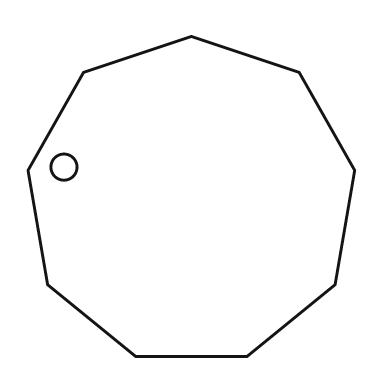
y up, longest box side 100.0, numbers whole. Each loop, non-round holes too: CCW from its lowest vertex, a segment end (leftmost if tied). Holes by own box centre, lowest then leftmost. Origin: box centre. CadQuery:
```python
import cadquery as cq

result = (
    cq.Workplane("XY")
    .moveTo(-17.0, -49.0)
    .lineTo(17.0, -49.0)
    .lineTo(44.0, -27.0)
    .lineTo(50.0, 8.0)
    .lineTo(33.0, 38.0)
    .lineTo(0.0, 49.0)
    .lineTo(-33.0, 38.0)
    .lineTo(-50.0, 8.0)
    .lineTo(-44.0, -27.0)
    .close()
    .moveTo(-39.0, 9.0)
    .circle(4.0)
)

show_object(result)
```